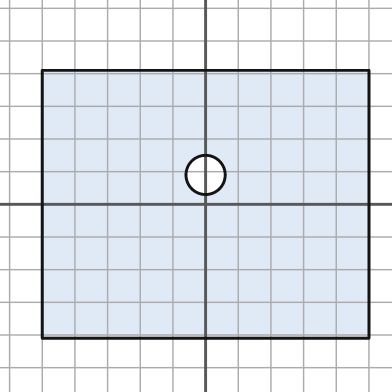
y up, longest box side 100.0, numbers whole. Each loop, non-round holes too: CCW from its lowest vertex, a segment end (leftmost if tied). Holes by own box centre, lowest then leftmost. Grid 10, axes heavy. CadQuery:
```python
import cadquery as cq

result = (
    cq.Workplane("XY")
    .moveTo(-50.0, -41.0)
    .lineTo(50.0, -41.0)
    .lineTo(50.0, 41.0)
    .lineTo(-50.0, 41.0)
    .close()
    .moveTo(0.0, 9.0)
    .circle(6.0)
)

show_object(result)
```